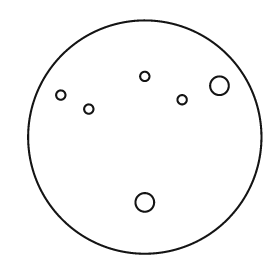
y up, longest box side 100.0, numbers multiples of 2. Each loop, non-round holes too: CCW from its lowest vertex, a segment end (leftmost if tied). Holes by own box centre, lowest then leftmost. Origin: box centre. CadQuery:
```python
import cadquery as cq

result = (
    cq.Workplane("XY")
    .moveTo(0.0, 0.0)
    .circle(50.0)
    .moveTo(0.0, -28.0)
    .circle(4.0)
    .moveTo(-24.0, 12.0)
    .circle(2.0)
    .moveTo(16.0, 16.0)
    .circle(2.0)
    .moveTo(-36.0, 18.0)
    .circle(2.0)
    .moveTo(32.0, 22.0)
    .circle(4.0)
    .moveTo(0.0, 26.0)
    .circle(2.0)
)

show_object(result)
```